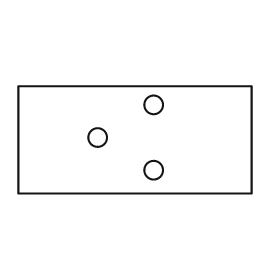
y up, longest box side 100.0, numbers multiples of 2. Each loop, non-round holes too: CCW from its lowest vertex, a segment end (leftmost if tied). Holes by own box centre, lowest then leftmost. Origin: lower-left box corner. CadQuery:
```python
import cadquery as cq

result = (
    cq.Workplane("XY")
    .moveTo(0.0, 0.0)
    .lineTo(100.0, 0.0)
    .lineTo(100.0, 46.0)
    .lineTo(0.0, 46.0)
    .close()
    .moveTo(58.0, 10.0)
    .circle(4.0)
    .moveTo(34.0, 24.0)
    .circle(4.0)
    .moveTo(58.0, 38.0)
    .circle(4.0)
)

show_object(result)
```